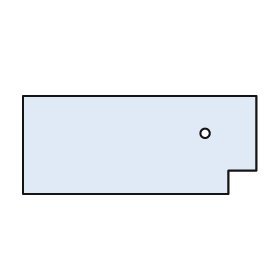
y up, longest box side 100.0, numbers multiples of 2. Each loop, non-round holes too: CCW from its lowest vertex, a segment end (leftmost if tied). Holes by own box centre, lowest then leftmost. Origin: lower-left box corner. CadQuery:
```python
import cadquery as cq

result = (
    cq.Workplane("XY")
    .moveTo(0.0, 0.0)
    .lineTo(88.0, 0.0)
    .lineTo(88.0, 10.0)
    .lineTo(100.0, 10.0)
    .lineTo(100.0, 42.0)
    .lineTo(0.0, 42.0)
    .close()
    .moveTo(78.0, 26.0)
    .circle(2.0)
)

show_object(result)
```